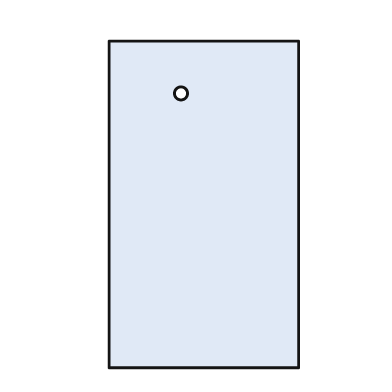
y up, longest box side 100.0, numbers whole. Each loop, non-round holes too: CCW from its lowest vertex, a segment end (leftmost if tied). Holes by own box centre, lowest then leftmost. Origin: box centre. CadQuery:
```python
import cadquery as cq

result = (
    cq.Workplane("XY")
    .moveTo(-29.0, -50.0)
    .lineTo(29.0, -50.0)
    .lineTo(29.0, 50.0)
    .lineTo(-29.0, 50.0)
    .close()
    .moveTo(-7.0, 34.0)
    .circle(2.0)
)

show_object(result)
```